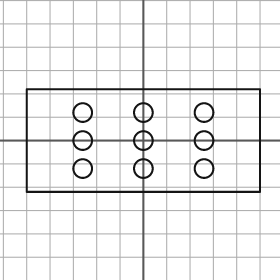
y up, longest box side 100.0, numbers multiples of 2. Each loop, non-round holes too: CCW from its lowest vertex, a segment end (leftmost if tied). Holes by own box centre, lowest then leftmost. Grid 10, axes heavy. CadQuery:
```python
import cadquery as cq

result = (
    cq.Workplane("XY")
    .moveTo(-50.0, -22.0)
    .lineTo(50.0, -22.0)
    .lineTo(50.0, 22.0)
    .lineTo(-50.0, 22.0)
    .close()
    .moveTo(-26.0, -12.0)
    .circle(4.0)
    .moveTo(0.0, -12.0)
    .circle(4.0)
    .moveTo(26.0, -12.0)
    .circle(4.0)
    .moveTo(-26.0, 0.0)
    .circle(4.0)
    .moveTo(0.0, 0.0)
    .circle(4.0)
    .moveTo(26.0, 0.0)
    .circle(4.0)
    .moveTo(-26.0, 12.0)
    .circle(4.0)
    .moveTo(0.0, 12.0)
    .circle(4.0)
    .moveTo(26.0, 12.0)
    .circle(4.0)
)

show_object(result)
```